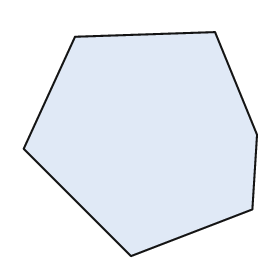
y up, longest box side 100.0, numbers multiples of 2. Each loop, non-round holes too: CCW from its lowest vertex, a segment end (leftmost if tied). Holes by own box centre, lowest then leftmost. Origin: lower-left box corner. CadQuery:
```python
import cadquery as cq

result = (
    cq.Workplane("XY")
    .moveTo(46.0, 0.0)
    .lineTo(98.0, 20.0)
    .lineTo(100.0, 52.0)
    .lineTo(82.0, 96.0)
    .lineTo(22.0, 94.0)
    .lineTo(0.0, 46.0)
    .close()
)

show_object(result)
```